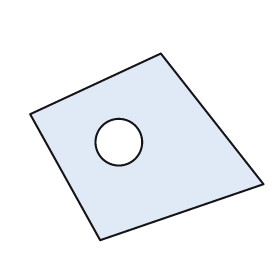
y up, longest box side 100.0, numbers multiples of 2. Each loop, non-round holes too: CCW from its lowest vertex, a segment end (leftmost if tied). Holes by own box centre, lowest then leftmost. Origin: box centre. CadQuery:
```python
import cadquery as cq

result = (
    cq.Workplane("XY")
    .moveTo(-20.0, -40.0)
    .lineTo(50.0, -16.0)
    .lineTo(6.0, 40.0)
    .lineTo(-50.0, 14.0)
    .close()
    .moveTo(-12.0, 2.0)
    .circle(10.0)
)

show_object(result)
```